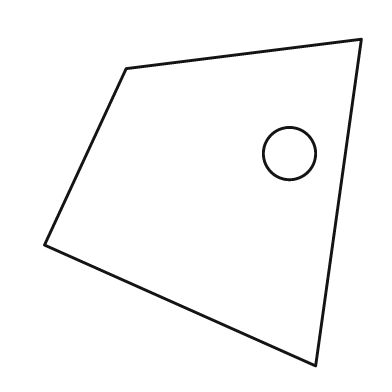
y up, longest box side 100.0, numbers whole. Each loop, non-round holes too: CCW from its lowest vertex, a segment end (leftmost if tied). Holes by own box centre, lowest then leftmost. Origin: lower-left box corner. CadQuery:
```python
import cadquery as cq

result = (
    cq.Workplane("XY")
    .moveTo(83.0, 0.0)
    .lineTo(97.0, 100.0)
    .lineTo(25.0, 91.0)
    .lineTo(0.0, 37.0)
    .close()
    .moveTo(75.0, 65.0)
    .circle(8.0)
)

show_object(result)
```